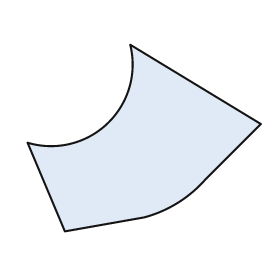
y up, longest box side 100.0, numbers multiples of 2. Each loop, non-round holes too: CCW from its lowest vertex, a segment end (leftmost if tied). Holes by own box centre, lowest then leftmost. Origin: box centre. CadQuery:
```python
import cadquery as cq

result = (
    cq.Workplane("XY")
    .moveTo(-34.0, -40.0)
    .lineTo(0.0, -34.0)
    .threePointArc((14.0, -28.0), (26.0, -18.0))
    .lineTo(50.0, 6.0)
    .lineTo(-6.0, 40.0)
    .threePointArc((-16.0, 6.0), (-50.0, -2.0))
    .close()
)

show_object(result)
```